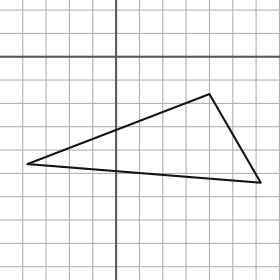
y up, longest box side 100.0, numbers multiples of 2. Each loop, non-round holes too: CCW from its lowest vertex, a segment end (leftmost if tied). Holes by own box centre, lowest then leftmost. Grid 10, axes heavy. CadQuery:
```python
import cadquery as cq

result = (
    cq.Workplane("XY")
    .moveTo(62.0, -54.0)
    .lineTo(40.0, -16.0)
    .lineTo(-38.0, -46.0)
    .close()
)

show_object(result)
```